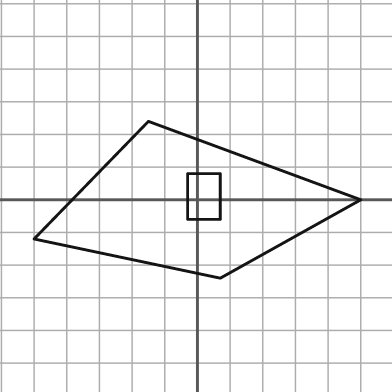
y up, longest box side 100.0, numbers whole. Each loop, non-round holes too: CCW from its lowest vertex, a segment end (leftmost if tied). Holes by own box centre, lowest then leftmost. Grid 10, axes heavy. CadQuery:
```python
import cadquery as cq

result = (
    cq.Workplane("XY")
    .moveTo(7.0, -24.0)
    .lineTo(50.0, 0.0)
    .lineTo(-15.0, 24.0)
    .lineTo(-50.0, -12.0)
    .close()
    .moveTo(-3.0, -6.0)
    .lineTo(7.0, -6.0)
    .lineTo(7.0, 8.0)
    .lineTo(-3.0, 8.0)
    .close()
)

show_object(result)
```